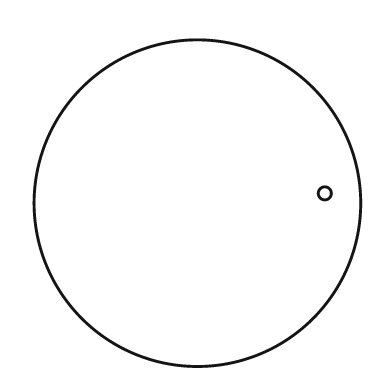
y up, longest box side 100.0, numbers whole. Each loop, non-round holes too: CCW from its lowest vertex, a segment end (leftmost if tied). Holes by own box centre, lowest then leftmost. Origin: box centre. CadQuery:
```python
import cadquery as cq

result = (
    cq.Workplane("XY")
    .moveTo(0.0, 0.0)
    .circle(50.0)
    .moveTo(39.0, 3.0)
    .circle(2.0)
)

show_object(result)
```